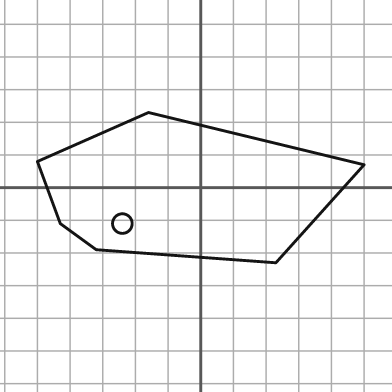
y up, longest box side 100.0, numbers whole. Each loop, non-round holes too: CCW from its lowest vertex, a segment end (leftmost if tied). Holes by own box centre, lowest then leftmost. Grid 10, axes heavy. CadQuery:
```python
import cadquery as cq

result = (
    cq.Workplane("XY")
    .moveTo(23.0, -23.0)
    .lineTo(50.0, 7.0)
    .lineTo(-16.0, 23.0)
    .lineTo(-50.0, 8.0)
    .lineTo(-43.0, -11.0)
    .lineTo(-32.0, -19.0)
    .close()
    .moveTo(-24.0, -11.0)
    .circle(3.0)
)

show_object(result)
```